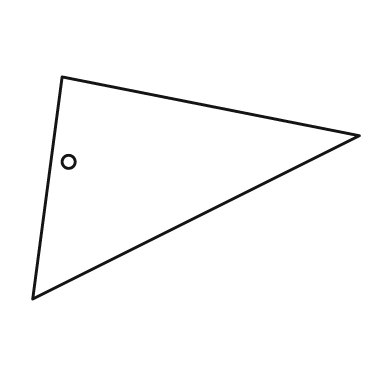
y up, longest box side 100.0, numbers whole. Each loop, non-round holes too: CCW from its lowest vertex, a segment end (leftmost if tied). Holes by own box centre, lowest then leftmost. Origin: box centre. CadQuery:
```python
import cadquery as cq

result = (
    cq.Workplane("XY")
    .moveTo(-50.0, -34.0)
    .lineTo(50.0, 16.0)
    .lineTo(-41.0, 34.0)
    .close()
    .moveTo(-39.0, 8.0)
    .circle(2.0)
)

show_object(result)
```